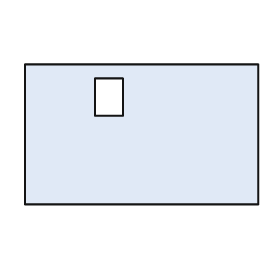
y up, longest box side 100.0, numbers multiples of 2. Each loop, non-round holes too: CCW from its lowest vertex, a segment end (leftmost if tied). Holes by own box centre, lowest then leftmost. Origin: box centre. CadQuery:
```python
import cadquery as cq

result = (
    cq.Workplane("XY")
    .moveTo(-50.0, -30.0)
    .lineTo(50.0, -30.0)
    .lineTo(50.0, 30.0)
    .lineTo(-50.0, 30.0)
    .close()
    .moveTo(-20.0, 8.0)
    .lineTo(-8.0, 8.0)
    .lineTo(-8.0, 24.0)
    .lineTo(-20.0, 24.0)
    .close()
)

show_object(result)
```